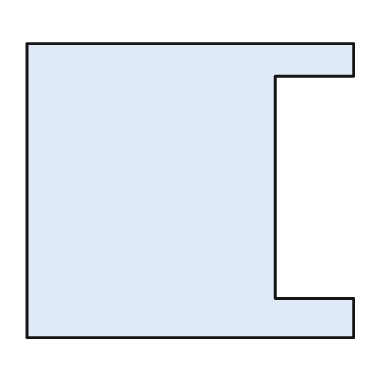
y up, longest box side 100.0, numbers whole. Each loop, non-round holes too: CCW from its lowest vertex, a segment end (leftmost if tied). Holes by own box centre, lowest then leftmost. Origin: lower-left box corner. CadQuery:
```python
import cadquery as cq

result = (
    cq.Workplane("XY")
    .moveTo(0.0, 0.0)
    .lineTo(100.0, 0.0)
    .lineTo(100.0, 12.0)
    .lineTo(76.0, 12.0)
    .lineTo(76.0, 80.0)
    .lineTo(100.0, 80.0)
    .lineTo(100.0, 90.0)
    .lineTo(0.0, 90.0)
    .close()
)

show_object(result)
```